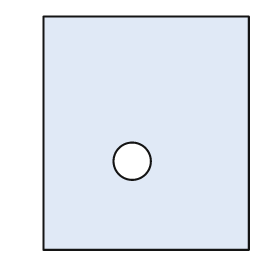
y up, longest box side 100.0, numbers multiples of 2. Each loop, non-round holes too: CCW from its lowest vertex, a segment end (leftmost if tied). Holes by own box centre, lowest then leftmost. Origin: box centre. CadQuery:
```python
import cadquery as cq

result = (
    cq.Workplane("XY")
    .moveTo(-44.0, -50.0)
    .lineTo(44.0, -50.0)
    .lineTo(44.0, 50.0)
    .lineTo(-44.0, 50.0)
    .close()
    .moveTo(-6.0, -12.0)
    .circle(8.0)
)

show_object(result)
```